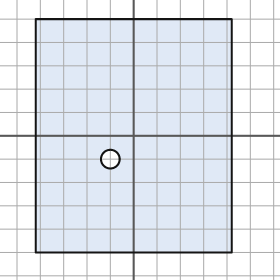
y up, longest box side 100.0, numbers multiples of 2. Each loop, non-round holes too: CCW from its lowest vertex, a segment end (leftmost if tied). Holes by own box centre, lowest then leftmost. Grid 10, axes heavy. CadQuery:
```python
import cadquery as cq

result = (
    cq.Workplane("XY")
    .moveTo(-42.0, -50.0)
    .lineTo(42.0, -50.0)
    .lineTo(42.0, 50.0)
    .lineTo(-42.0, 50.0)
    .close()
    .moveTo(-10.0, -10.0)
    .circle(4.0)
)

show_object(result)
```